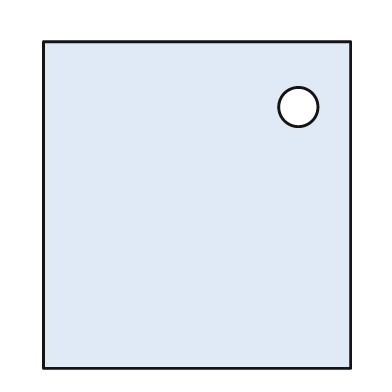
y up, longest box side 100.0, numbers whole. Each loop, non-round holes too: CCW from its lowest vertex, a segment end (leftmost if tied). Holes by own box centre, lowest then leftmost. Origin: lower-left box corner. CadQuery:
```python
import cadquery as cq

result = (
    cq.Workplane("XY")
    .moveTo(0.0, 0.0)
    .lineTo(94.0, 0.0)
    .lineTo(94.0, 100.0)
    .lineTo(0.0, 100.0)
    .close()
    .moveTo(78.0, 80.0)
    .circle(6.0)
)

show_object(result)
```